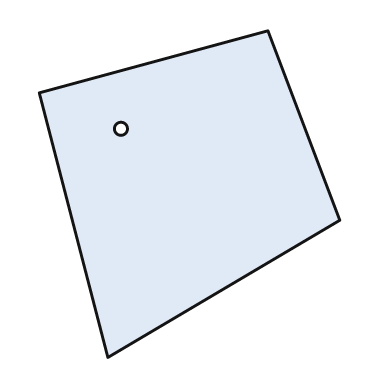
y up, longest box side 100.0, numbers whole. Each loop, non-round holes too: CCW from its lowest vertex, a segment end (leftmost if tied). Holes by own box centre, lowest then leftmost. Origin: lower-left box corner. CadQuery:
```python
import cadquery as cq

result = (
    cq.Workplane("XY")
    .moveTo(21.0, 0.0)
    .lineTo(92.0, 42.0)
    .lineTo(70.0, 100.0)
    .lineTo(0.0, 81.0)
    .close()
    .moveTo(25.0, 70.0)
    .circle(2.0)
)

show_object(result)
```